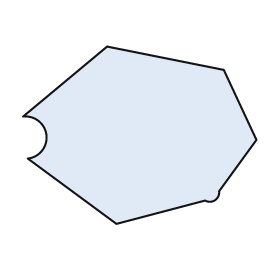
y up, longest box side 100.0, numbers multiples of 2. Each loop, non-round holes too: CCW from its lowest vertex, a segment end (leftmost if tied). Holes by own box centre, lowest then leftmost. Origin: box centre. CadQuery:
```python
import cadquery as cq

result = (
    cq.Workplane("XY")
    .moveTo(-10.0, -38.0)
    .lineTo(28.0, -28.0)
    .threePointArc((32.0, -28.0), (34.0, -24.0))
    .lineTo(50.0, -2.0)
    .lineTo(36.0, 28.0)
    .lineTo(-14.0, 38.0)
    .lineTo(-50.0, 8.0)
    .threePointArc((-40.0, 0.0), (-48.0, -10.0))
    .close()
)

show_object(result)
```